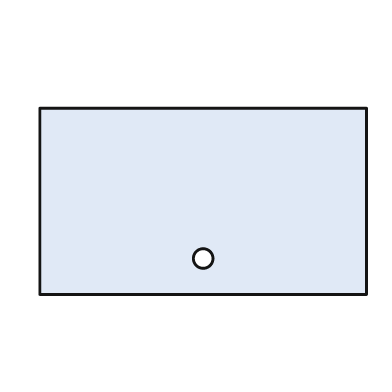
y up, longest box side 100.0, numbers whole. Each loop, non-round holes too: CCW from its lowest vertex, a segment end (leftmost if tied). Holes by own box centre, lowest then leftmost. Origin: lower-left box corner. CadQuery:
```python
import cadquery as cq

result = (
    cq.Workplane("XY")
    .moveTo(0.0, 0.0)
    .lineTo(100.0, 0.0)
    .lineTo(100.0, 57.0)
    .lineTo(0.0, 57.0)
    .close()
    .moveTo(50.0, 11.0)
    .circle(3.0)
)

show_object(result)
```